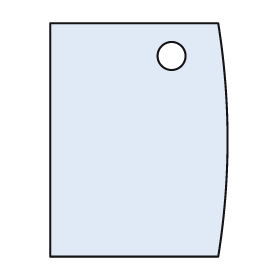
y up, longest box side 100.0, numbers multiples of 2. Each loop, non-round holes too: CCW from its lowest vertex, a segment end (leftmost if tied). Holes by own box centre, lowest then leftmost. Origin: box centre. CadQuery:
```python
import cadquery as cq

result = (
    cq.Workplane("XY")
    .moveTo(-38.0, -50.0)
    .lineTo(34.0, -50.0)
    .threePointArc((38.0, 0.0), (34.0, 50.0))
    .lineTo(-38.0, 50.0)
    .close()
    .moveTo(14.0, 36.0)
    .circle(6.0)
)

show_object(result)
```